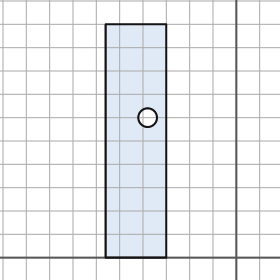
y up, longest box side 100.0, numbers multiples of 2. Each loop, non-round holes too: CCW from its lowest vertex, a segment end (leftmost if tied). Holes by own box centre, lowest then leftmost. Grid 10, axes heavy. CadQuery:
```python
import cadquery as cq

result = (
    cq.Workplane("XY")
    .moveTo(-56.0, 0.0)
    .lineTo(-30.0, 0.0)
    .lineTo(-30.0, 100.0)
    .lineTo(-56.0, 100.0)
    .close()
    .moveTo(-38.0, 60.0)
    .circle(4.0)
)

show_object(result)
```